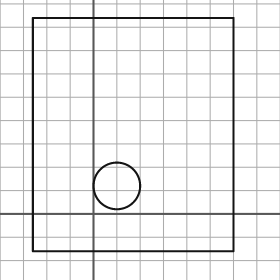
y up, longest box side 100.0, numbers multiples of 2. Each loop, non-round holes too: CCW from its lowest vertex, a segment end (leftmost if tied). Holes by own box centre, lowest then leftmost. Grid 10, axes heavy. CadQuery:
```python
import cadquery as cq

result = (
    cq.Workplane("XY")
    .moveTo(-26.0, -16.0)
    .lineTo(60.0, -16.0)
    .lineTo(60.0, 84.0)
    .lineTo(-26.0, 84.0)
    .close()
    .moveTo(10.0, 12.0)
    .circle(10.0)
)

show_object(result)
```